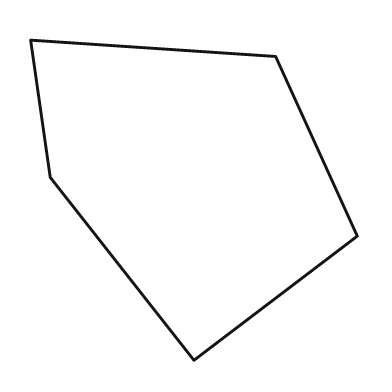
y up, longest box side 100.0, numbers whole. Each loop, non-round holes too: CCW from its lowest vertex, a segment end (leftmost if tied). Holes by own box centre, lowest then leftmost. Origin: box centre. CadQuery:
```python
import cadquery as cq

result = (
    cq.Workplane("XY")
    .moveTo(0.0, -49.0)
    .lineTo(50.0, -11.0)
    .lineTo(25.0, 44.0)
    .lineTo(-50.0, 49.0)
    .lineTo(-44.0, 7.0)
    .close()
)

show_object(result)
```